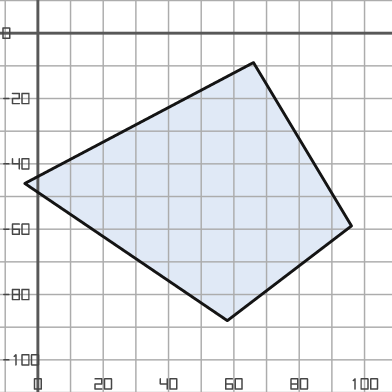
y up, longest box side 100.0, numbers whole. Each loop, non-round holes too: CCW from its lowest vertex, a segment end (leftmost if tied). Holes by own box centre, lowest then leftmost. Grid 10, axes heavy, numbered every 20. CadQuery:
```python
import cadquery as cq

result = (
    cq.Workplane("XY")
    .moveTo(58.0, -88.0)
    .lineTo(96.0, -59.0)
    .lineTo(66.0, -9.0)
    .lineTo(-4.0, -46.0)
    .close()
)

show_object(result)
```